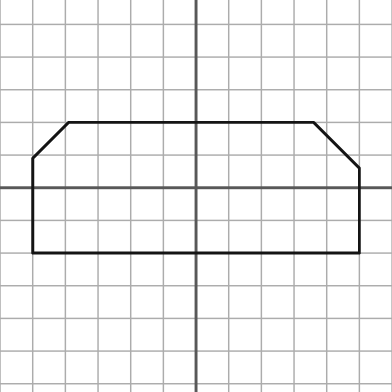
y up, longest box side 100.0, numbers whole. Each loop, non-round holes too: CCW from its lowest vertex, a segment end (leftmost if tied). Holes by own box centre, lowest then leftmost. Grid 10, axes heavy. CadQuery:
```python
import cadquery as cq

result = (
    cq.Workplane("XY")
    .moveTo(-50.0, -20.0)
    .lineTo(50.0, -20.0)
    .lineTo(50.0, 6.0)
    .lineTo(36.0, 20.0)
    .lineTo(-39.0, 20.0)
    .lineTo(-50.0, 9.0)
    .close()
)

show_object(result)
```